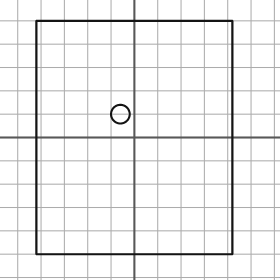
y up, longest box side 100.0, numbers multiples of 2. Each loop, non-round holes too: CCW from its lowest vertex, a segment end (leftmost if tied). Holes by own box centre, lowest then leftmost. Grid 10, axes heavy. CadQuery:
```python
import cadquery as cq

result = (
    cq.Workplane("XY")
    .moveTo(-42.0, -50.0)
    .lineTo(42.0, -50.0)
    .lineTo(42.0, 50.0)
    .lineTo(-42.0, 50.0)
    .close()
    .moveTo(-6.0, 10.0)
    .circle(4.0)
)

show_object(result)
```